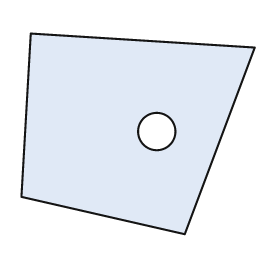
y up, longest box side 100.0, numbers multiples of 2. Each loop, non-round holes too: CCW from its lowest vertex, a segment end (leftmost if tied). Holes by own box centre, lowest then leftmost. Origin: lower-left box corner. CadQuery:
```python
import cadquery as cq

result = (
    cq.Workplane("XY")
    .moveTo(70.0, 0.0)
    .lineTo(100.0, 80.0)
    .lineTo(4.0, 86.0)
    .lineTo(0.0, 16.0)
    .close()
    .moveTo(58.0, 44.0)
    .circle(8.0)
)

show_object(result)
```